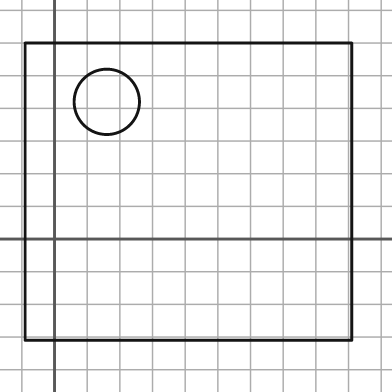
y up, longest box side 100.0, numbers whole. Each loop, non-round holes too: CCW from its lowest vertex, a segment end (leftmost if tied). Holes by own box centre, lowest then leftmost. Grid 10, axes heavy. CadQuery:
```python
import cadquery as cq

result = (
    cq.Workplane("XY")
    .moveTo(-9.0, -31.0)
    .lineTo(91.0, -31.0)
    .lineTo(91.0, 60.0)
    .lineTo(-9.0, 60.0)
    .close()
    .moveTo(16.0, 42.0)
    .circle(10.0)
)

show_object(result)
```